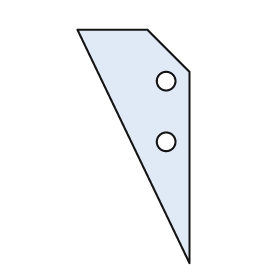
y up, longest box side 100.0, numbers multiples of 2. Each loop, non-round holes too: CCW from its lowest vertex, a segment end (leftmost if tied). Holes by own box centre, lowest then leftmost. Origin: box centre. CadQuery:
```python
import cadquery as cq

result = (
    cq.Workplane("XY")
    .moveTo(24.0, -50.0)
    .lineTo(24.0, 32.0)
    .lineTo(6.0, 50.0)
    .lineTo(-24.0, 50.0)
    .close()
    .moveTo(14.0, 2.0)
    .circle(4.0)
    .moveTo(14.0, 28.0)
    .circle(4.0)
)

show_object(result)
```